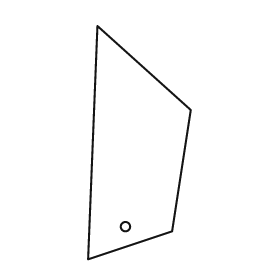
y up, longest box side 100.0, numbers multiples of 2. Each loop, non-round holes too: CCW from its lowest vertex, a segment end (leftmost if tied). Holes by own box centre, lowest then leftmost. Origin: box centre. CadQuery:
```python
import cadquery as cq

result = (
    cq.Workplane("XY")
    .moveTo(-22.0, -50.0)
    .lineTo(14.0, -38.0)
    .lineTo(22.0, 14.0)
    .lineTo(-18.0, 50.0)
    .close()
    .moveTo(-6.0, -36.0)
    .circle(2.0)
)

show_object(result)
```